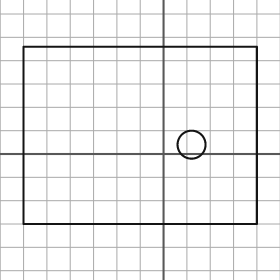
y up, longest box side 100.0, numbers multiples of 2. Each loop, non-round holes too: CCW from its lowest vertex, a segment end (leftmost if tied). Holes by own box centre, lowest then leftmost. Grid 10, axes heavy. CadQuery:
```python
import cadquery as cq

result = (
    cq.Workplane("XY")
    .moveTo(-60.0, -30.0)
    .lineTo(40.0, -30.0)
    .lineTo(40.0, 46.0)
    .lineTo(-60.0, 46.0)
    .close()
    .moveTo(12.0, 4.0)
    .circle(6.0)
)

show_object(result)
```